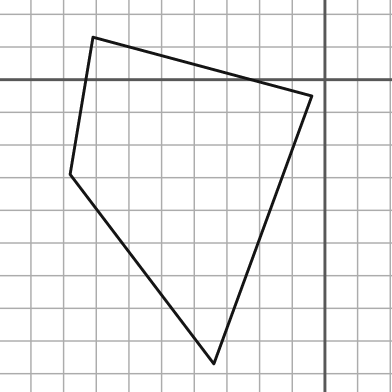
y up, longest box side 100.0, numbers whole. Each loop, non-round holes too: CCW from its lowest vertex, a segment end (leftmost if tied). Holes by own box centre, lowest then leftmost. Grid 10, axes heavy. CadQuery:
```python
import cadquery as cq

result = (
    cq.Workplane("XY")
    .moveTo(-34.0, -87.0)
    .lineTo(-4.0, -5.0)
    .lineTo(-71.0, 13.0)
    .lineTo(-78.0, -29.0)
    .close()
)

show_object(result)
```